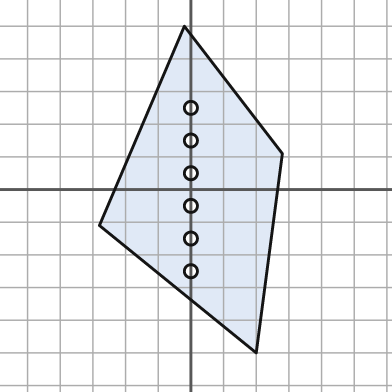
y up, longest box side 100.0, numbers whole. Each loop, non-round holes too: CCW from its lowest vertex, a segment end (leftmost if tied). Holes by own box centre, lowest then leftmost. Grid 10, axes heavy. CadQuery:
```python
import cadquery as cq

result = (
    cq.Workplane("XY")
    .moveTo(20.0, -50.0)
    .lineTo(28.0, 11.0)
    .lineTo(-2.0, 50.0)
    .lineTo(-28.0, -11.0)
    .close()
    .moveTo(0.0, -25.0)
    .circle(2.0)
    .moveTo(0.0, -15.0)
    .circle(2.0)
    .moveTo(0.0, -5.0)
    .circle(2.0)
    .moveTo(0.0, 5.0)
    .circle(2.0)
    .moveTo(0.0, 15.0)
    .circle(2.0)
    .moveTo(0.0, 25.0)
    .circle(2.0)
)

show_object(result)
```